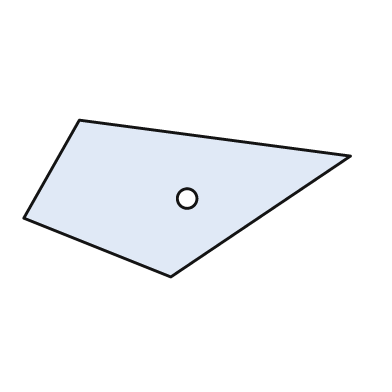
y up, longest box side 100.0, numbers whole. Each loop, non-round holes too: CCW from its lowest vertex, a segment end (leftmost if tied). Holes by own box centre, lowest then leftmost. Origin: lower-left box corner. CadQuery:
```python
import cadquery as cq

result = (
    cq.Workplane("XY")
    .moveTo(45.0, 0.0)
    .lineTo(100.0, 37.0)
    .lineTo(17.0, 48.0)
    .lineTo(0.0, 18.0)
    .close()
    .moveTo(50.0, 24.0)
    .circle(3.0)
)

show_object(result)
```